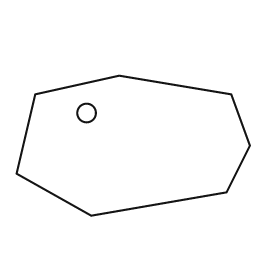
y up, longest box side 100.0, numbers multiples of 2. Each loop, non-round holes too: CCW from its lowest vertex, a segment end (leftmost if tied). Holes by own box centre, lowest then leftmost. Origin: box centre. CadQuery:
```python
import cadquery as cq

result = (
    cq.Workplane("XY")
    .moveTo(-18.0, -30.0)
    .lineTo(40.0, -20.0)
    .lineTo(50.0, 0.0)
    .lineTo(42.0, 22.0)
    .lineTo(-6.0, 30.0)
    .lineTo(-42.0, 22.0)
    .lineTo(-50.0, -12.0)
    .close()
    .moveTo(-20.0, 14.0)
    .circle(4.0)
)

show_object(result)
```